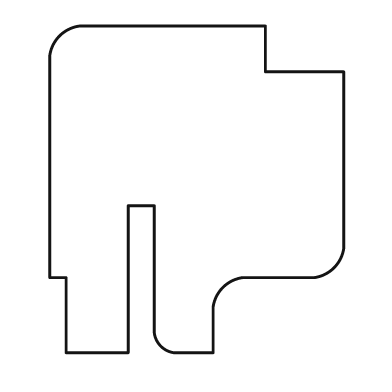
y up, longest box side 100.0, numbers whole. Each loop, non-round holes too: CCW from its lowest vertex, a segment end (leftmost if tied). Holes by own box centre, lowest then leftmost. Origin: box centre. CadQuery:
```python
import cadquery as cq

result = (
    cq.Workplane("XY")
    .moveTo(-40.0, -50.0)
    .lineTo(-21.0, -50.0)
    .lineTo(-21.0, -5.0)
    .lineTo(-13.0, -5.0)
    .lineTo(-13.0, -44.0)
    .threePointArc((-11.0, -48.0), (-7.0, -50.0))
    .lineTo(5.0, -50.0)
    .lineTo(5.0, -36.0)
    .threePointArc((8.0, -30.0), (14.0, -27.0))
    .lineTo(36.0, -27.0)
    .threePointArc((42.0, -24.0), (45.0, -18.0))
    .lineTo(45.0, 36.0)
    .lineTo(21.0, 36.0)
    .lineTo(21.0, 50.0)
    .lineTo(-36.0, 50.0)
    .threePointArc((-42.0, 47.0), (-45.0, 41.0))
    .lineTo(-45.0, -27.0)
    .lineTo(-40.0, -27.0)
    .close()
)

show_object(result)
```